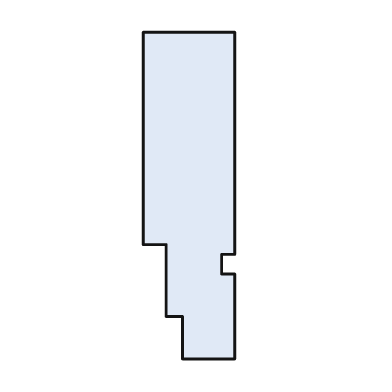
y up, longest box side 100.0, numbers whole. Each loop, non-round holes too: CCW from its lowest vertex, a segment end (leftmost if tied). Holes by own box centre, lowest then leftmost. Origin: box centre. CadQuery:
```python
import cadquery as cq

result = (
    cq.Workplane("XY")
    .moveTo(-2.0, -50.0)
    .lineTo(14.0, -50.0)
    .lineTo(14.0, -24.0)
    .lineTo(10.0, -24.0)
    .lineTo(10.0, -18.0)
    .lineTo(14.0, -18.0)
    .lineTo(14.0, 50.0)
    .lineTo(-14.0, 50.0)
    .lineTo(-14.0, -15.0)
    .lineTo(-7.0, -15.0)
    .lineTo(-7.0, -37.0)
    .lineTo(-2.0, -37.0)
    .close()
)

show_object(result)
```